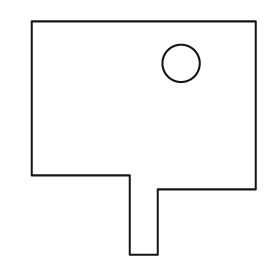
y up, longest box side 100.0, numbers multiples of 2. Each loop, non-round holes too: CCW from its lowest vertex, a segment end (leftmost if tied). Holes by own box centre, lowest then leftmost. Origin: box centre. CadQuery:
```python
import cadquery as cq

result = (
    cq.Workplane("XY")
    .moveTo(-6.0, -50.0)
    .lineTo(6.0, -50.0)
    .lineTo(6.0, -22.0)
    .lineTo(48.0, -22.0)
    .lineTo(48.0, 50.0)
    .lineTo(-48.0, 50.0)
    .lineTo(-48.0, -16.0)
    .lineTo(-6.0, -16.0)
    .close()
    .moveTo(16.0, 32.0)
    .circle(8.0)
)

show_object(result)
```